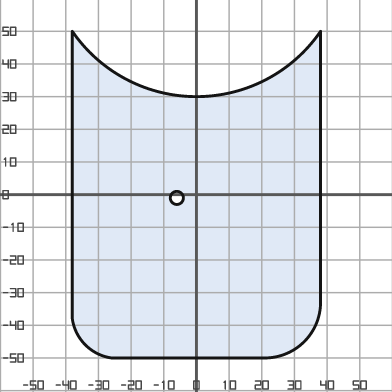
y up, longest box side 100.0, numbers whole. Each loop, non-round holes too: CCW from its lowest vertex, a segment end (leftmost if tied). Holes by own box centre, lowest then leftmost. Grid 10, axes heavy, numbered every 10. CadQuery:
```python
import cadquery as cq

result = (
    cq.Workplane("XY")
    .moveTo(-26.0, -50.0)
    .lineTo(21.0, -50.0)
    .threePointArc((33.0, -45.0), (38.0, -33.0))
    .lineTo(38.0, 50.0)
    .threePointArc((0.0, 30.0), (-38.0, 50.0))
    .lineTo(-38.0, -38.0)
    .threePointArc((-34.0, -46.0), (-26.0, -50.0))
    .close()
    .moveTo(-6.0, -1.0)
    .circle(2.0)
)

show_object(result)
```